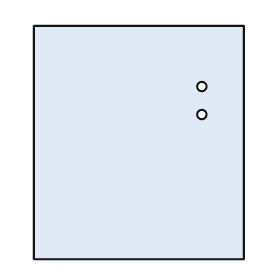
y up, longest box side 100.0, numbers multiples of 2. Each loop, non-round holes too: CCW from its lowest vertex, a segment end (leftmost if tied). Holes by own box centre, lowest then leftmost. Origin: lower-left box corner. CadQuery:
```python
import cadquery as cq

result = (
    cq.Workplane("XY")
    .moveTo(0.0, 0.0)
    .lineTo(90.0, 0.0)
    .lineTo(90.0, 100.0)
    .lineTo(0.0, 100.0)
    .close()
    .moveTo(72.0, 62.0)
    .circle(2.0)
    .moveTo(72.0, 74.0)
    .circle(2.0)
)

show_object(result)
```